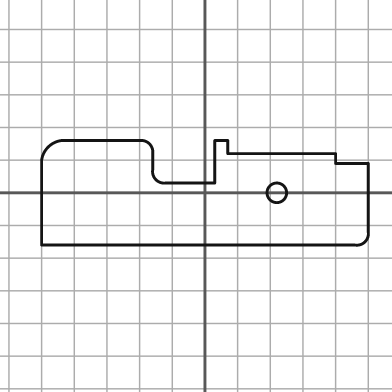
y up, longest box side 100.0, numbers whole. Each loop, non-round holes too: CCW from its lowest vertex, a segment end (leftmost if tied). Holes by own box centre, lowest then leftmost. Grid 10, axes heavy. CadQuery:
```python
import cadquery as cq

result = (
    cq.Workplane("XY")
    .moveTo(-50.0, -16.0)
    .lineTo(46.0, -16.0)
    .threePointArc((49.0, -15.0), (50.0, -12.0))
    .lineTo(50.0, 9.0)
    .lineTo(40.0, 9.0)
    .lineTo(40.0, 12.0)
    .lineTo(7.0, 12.0)
    .lineTo(7.0, 16.0)
    .lineTo(3.0, 16.0)
    .lineTo(3.0, 3.0)
    .lineTo(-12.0, 3.0)
    .threePointArc((-15.0, 4.0), (-16.0, 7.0))
    .lineTo(-16.0, 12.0)
    .threePointArc((-17.0, 15.0), (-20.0, 16.0))
    .lineTo(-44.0, 16.0)
    .threePointArc((-48.0, 14.0), (-50.0, 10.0))
    .close()
    .moveTo(22.0, 0.0)
    .circle(3.0)
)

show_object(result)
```